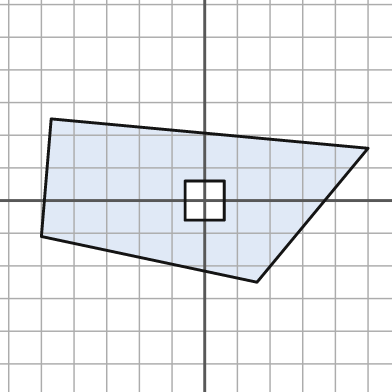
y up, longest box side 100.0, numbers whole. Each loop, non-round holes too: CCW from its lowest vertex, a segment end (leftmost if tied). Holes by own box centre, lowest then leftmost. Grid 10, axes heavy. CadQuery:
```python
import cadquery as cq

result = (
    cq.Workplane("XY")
    .moveTo(16.0, -25.0)
    .lineTo(50.0, 16.0)
    .lineTo(-47.0, 25.0)
    .lineTo(-50.0, -11.0)
    .close()
    .moveTo(-6.0, -6.0)
    .lineTo(6.0, -6.0)
    .lineTo(6.0, 6.0)
    .lineTo(-6.0, 6.0)
    .close()
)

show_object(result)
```